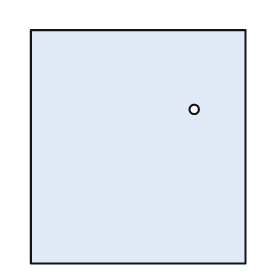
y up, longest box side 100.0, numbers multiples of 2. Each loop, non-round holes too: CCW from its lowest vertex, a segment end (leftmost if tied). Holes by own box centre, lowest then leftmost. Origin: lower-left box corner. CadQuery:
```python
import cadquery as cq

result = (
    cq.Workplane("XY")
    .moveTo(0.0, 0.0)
    .lineTo(92.0, 0.0)
    .lineTo(92.0, 100.0)
    .lineTo(0.0, 100.0)
    .close()
    .moveTo(70.0, 66.0)
    .circle(2.0)
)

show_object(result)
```